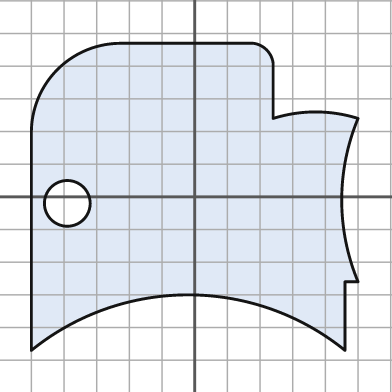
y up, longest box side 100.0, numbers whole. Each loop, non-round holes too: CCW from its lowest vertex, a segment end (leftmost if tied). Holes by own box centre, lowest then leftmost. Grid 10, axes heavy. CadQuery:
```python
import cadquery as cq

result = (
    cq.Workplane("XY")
    .moveTo(-50.0, -47.0)
    .threePointArc((-2.0, -30.0), (46.0, -47.0))
    .lineTo(46.0, -26.0)
    .lineTo(50.0, -26.0)
    .threePointArc((45.0, -1.0), (50.0, 24.0))
    .threePointArc((37.0, 26.0), (24.0, 24.0))
    .lineTo(24.0, 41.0)
    .threePointArc((22.0, 45.0), (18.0, 47.0))
    .lineTo(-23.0, 47.0)
    .threePointArc((-42.0, 39.0), (-50.0, 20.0))
    .close()
    .moveTo(-39.0, -2.0)
    .circle(7.0)
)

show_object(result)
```